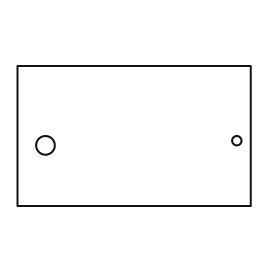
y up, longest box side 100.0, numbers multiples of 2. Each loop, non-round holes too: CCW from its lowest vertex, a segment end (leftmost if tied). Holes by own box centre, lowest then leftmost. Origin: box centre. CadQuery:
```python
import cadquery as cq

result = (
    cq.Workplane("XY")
    .moveTo(-50.0, -30.0)
    .lineTo(50.0, -30.0)
    .lineTo(50.0, 30.0)
    .lineTo(-50.0, 30.0)
    .close()
    .moveTo(-38.0, -4.0)
    .circle(4.0)
    .moveTo(44.0, -2.0)
    .circle(2.0)
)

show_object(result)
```